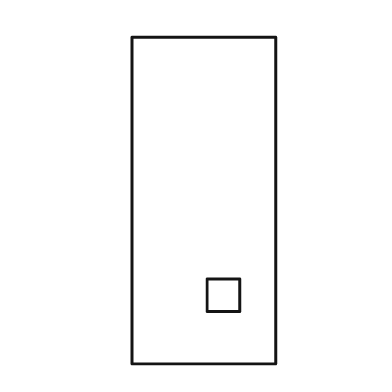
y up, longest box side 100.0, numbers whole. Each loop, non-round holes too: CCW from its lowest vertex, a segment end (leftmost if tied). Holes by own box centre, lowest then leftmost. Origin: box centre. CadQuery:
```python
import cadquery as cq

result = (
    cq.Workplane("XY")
    .moveTo(-22.0, -50.0)
    .lineTo(22.0, -50.0)
    .lineTo(22.0, 50.0)
    .lineTo(-22.0, 50.0)
    .close()
    .moveTo(1.0, -34.0)
    .lineTo(11.0, -34.0)
    .lineTo(11.0, -24.0)
    .lineTo(1.0, -24.0)
    .close()
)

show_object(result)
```